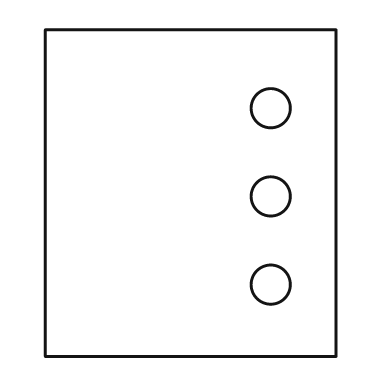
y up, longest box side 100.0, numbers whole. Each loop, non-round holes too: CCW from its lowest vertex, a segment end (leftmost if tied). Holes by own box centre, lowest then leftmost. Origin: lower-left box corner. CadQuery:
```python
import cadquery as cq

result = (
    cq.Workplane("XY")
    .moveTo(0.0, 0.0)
    .lineTo(89.0, 0.0)
    .lineTo(89.0, 100.0)
    .lineTo(0.0, 100.0)
    .close()
    .moveTo(69.0, 22.0)
    .circle(6.0)
    .moveTo(69.0, 49.0)
    .circle(6.0)
    .moveTo(69.0, 76.0)
    .circle(6.0)
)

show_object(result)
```